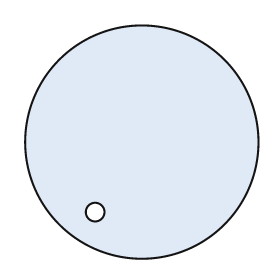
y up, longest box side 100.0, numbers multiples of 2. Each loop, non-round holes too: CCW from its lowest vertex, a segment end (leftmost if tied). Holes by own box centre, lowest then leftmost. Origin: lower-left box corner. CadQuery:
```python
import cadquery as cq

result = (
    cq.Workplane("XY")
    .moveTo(50.0, 50.0)
    .circle(50.0)
    .moveTo(30.0, 20.0)
    .circle(4.0)
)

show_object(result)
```